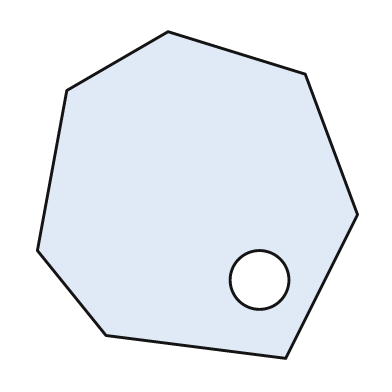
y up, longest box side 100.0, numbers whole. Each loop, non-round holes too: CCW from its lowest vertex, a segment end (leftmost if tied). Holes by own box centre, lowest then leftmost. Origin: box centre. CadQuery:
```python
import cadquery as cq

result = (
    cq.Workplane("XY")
    .moveTo(27.0, -50.0)
    .lineTo(49.0, -6.0)
    .lineTo(33.0, 37.0)
    .lineTo(-9.0, 50.0)
    .lineTo(-40.0, 32.0)
    .lineTo(-49.0, -17.0)
    .lineTo(-28.0, -43.0)
    .close()
    .moveTo(19.0, -26.0)
    .circle(9.0)
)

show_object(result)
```